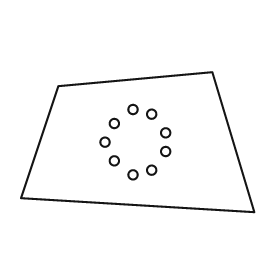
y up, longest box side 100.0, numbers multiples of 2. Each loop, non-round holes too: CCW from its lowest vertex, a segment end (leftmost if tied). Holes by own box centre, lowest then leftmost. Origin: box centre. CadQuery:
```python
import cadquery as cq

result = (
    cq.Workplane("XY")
    .moveTo(50.0, -30.0)
    .lineTo(32.0, 30.0)
    .lineTo(-34.0, 24.0)
    .lineTo(-50.0, -24.0)
    .close()
    .moveTo(-2.0, -14.0)
    .circle(2.0)
    .moveTo(6.0, -12.0)
    .circle(2.0)
    .moveTo(-10.0, -8.0)
    .circle(2.0)
    .moveTo(12.0, -4.0)
    .circle(2.0)
    .moveTo(-14.0, 0.0)
    .circle(2.0)
    .moveTo(12.0, 4.0)
    .circle(2.0)
    .moveTo(-10.0, 8.0)
    .circle(2.0)
    .moveTo(6.0, 12.0)
    .circle(2.0)
    .moveTo(-2.0, 14.0)
    .circle(2.0)
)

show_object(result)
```